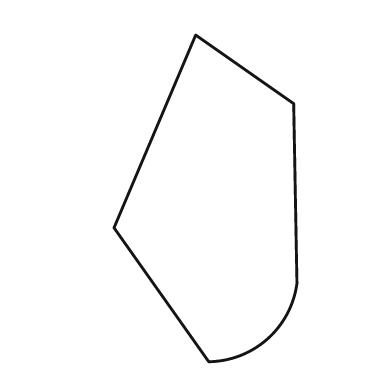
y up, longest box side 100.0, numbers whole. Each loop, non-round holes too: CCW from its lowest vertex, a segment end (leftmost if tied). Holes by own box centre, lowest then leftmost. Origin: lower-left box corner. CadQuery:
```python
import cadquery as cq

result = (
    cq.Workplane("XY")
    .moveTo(29.0, 0.0)
    .threePointArc((47.0, 7.0), (56.0, 24.0))
    .lineTo(55.0, 79.0)
    .lineTo(25.0, 100.0)
    .lineTo(0.0, 41.0)
    .close()
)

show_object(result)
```